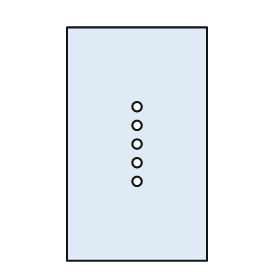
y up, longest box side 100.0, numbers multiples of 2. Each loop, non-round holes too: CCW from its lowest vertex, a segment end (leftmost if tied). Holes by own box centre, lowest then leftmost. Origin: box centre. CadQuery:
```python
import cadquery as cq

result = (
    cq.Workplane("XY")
    .moveTo(-30.0, -50.0)
    .lineTo(30.0, -50.0)
    .lineTo(30.0, 50.0)
    .lineTo(-30.0, 50.0)
    .close()
    .moveTo(0.0, -16.0)
    .circle(2.0)
    .moveTo(0.0, -8.0)
    .circle(2.0)
    .moveTo(0.0, 0.0)
    .circle(2.0)
    .moveTo(0.0, 8.0)
    .circle(2.0)
    .moveTo(0.0, 16.0)
    .circle(2.0)
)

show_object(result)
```